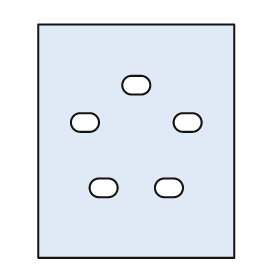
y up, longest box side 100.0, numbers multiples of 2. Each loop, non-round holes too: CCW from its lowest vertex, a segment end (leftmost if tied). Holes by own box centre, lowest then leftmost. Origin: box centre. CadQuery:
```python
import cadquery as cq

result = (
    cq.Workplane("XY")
    .moveTo(-42.0, -50.0)
    .lineTo(42.0, -50.0)
    .lineTo(42.0, 50.0)
    .lineTo(-42.0, 50.0)
    .close()
    .moveTo(-16.0, -24.0)
    .lineTo(-12.0, -24.0)
    .threePointArc((-8.0, -20.0), (-12.0, -16.0))
    .lineTo(-16.0, -16.0)
    .threePointArc((-20.0, -20.0), (-16.0, -24.0))
    .close()
    .moveTo(12.0, -24.0)
    .lineTo(16.0, -24.0)
    .threePointArc((20.0, -20.0), (16.0, -16.0))
    .lineTo(12.0, -16.0)
    .threePointArc((8.0, -20.0), (12.0, -24.0))
    .close()
    .moveTo(-24.0, 4.0)
    .lineTo(-20.0, 4.0)
    .threePointArc((-16.0, 8.0), (-20.0, 12.0))
    .lineTo(-24.0, 12.0)
    .threePointArc((-28.0, 8.0), (-24.0, 4.0))
    .close()
    .moveTo(20.0, 4.0)
    .lineTo(24.0, 4.0)
    .threePointArc((28.0, 8.0), (24.0, 12.0))
    .lineTo(20.0, 12.0)
    .threePointArc((16.0, 8.0), (20.0, 4.0))
    .close()
    .moveTo(-2.0, 20.0)
    .lineTo(2.0, 20.0)
    .threePointArc((6.0, 24.0), (2.0, 28.0))
    .lineTo(-2.0, 28.0)
    .threePointArc((-6.0, 24.0), (-2.0, 20.0))
    .close()
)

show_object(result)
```